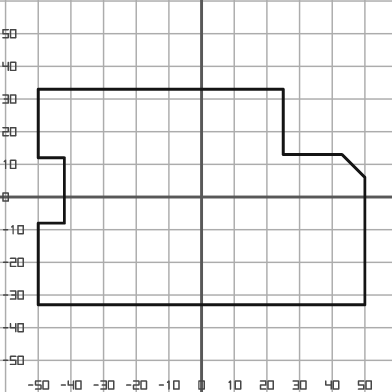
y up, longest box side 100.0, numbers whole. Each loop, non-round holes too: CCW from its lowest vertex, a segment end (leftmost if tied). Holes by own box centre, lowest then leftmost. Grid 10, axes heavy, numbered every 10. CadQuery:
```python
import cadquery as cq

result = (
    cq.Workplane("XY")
    .moveTo(-50.0, -33.0)
    .lineTo(50.0, -33.0)
    .lineTo(50.0, 6.0)
    .lineTo(43.0, 13.0)
    .lineTo(25.0, 13.0)
    .lineTo(25.0, 33.0)
    .lineTo(-50.0, 33.0)
    .lineTo(-50.0, 12.0)
    .lineTo(-42.0, 12.0)
    .lineTo(-42.0, -8.0)
    .lineTo(-50.0, -8.0)
    .close()
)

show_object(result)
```